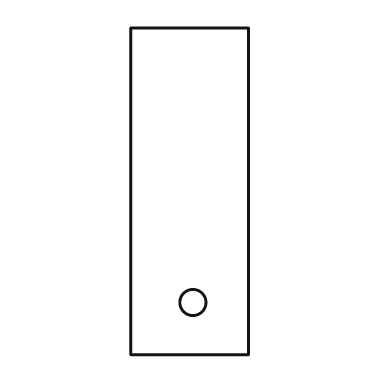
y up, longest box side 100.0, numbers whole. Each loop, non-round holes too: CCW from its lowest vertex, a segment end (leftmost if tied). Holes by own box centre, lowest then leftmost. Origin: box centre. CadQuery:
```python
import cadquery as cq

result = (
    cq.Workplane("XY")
    .moveTo(-18.0, -50.0)
    .lineTo(18.0, -50.0)
    .lineTo(18.0, 50.0)
    .lineTo(-18.0, 50.0)
    .close()
    .moveTo(1.0, -34.0)
    .circle(4.0)
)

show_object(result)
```